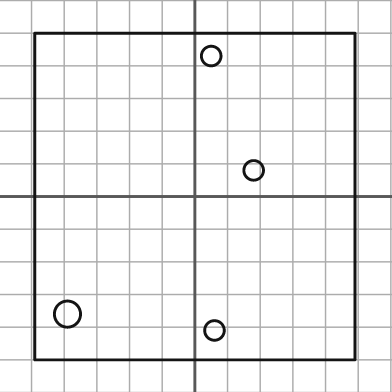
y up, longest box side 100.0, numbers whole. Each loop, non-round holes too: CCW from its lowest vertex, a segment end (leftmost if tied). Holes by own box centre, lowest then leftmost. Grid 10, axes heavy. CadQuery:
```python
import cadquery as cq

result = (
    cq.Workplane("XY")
    .moveTo(-49.0, -50.0)
    .lineTo(49.0, -50.0)
    .lineTo(49.0, 50.0)
    .lineTo(-49.0, 50.0)
    .close()
    .moveTo(6.0, -41.0)
    .circle(3.0)
    .moveTo(-39.0, -36.0)
    .circle(4.0)
    .moveTo(18.0, 8.0)
    .circle(3.0)
    .moveTo(5.0, 43.0)
    .circle(3.0)
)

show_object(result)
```